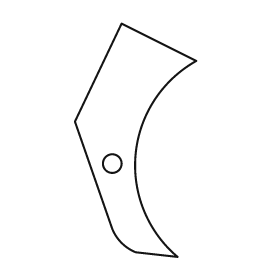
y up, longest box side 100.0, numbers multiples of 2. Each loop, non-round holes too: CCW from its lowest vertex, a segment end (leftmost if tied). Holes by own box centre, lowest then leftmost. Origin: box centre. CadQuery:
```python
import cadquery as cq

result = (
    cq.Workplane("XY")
    .moveTo(18.0, -50.0)
    .threePointArc((0.0, -6.0), (26.0, 34.0))
    .lineTo(-6.0, 50.0)
    .lineTo(-26.0, 8.0)
    .lineTo(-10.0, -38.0)
    .threePointArc((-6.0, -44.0), (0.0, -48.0))
    .close()
    .moveTo(-10.0, -10.0)
    .circle(4.0)
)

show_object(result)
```